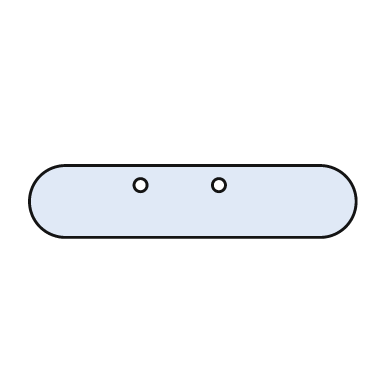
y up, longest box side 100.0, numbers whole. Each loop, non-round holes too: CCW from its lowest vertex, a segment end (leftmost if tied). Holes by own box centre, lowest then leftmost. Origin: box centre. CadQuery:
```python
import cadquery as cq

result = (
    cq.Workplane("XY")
    .moveTo(-39.0, -11.0)
    .lineTo(39.0, -11.0)
    .threePointArc((50.0, 0.0), (39.0, 11.0))
    .lineTo(-39.0, 11.0)
    .threePointArc((-50.0, 0.0), (-39.0, -11.0))
    .close()
    .moveTo(-16.0, 5.0)
    .circle(2.0)
    .moveTo(8.0, 5.0)
    .circle(2.0)
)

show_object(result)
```